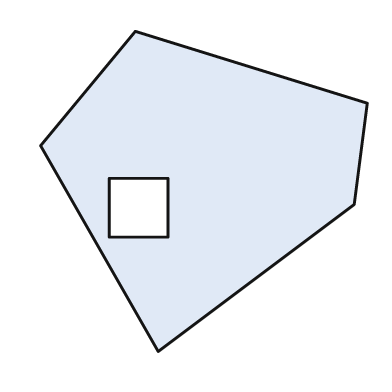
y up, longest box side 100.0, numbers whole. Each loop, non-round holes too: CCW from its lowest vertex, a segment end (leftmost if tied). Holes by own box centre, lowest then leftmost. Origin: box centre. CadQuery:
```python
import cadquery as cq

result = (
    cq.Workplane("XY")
    .moveTo(-14.0, -49.0)
    .lineTo(46.0, -4.0)
    .lineTo(50.0, 27.0)
    .lineTo(-21.0, 49.0)
    .lineTo(-50.0, 14.0)
    .close()
    .moveTo(-29.0, -14.0)
    .lineTo(-11.0, -14.0)
    .lineTo(-11.0, 4.0)
    .lineTo(-29.0, 4.0)
    .close()
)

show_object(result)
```